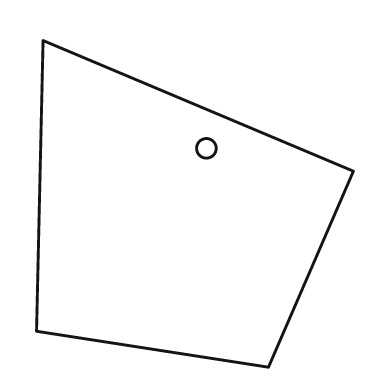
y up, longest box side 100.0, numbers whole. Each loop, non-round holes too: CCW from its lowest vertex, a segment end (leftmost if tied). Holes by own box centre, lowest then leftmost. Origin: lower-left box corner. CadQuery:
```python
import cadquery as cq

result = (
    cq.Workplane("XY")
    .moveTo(71.0, 0.0)
    .lineTo(97.0, 60.0)
    .lineTo(2.0, 100.0)
    .lineTo(0.0, 11.0)
    .close()
    .moveTo(52.0, 67.0)
    .circle(3.0)
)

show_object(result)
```